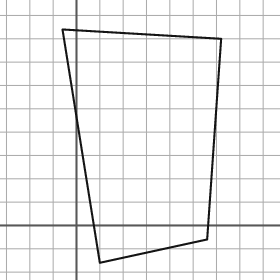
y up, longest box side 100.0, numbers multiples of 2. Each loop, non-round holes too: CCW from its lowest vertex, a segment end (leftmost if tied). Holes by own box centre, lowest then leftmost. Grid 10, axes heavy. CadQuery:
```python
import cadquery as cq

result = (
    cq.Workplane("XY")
    .moveTo(10.0, -16.0)
    .lineTo(56.0, -6.0)
    .lineTo(62.0, 80.0)
    .lineTo(-6.0, 84.0)
    .close()
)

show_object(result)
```